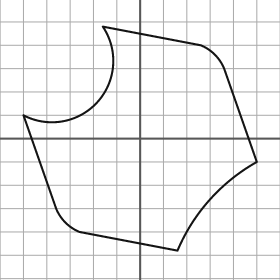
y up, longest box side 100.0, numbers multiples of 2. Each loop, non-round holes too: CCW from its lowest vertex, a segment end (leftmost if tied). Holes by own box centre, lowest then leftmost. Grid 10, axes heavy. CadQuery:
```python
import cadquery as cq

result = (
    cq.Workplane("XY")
    .moveTo(16.0, -48.0)
    .threePointArc((30.0, -26.0), (50.0, -10.0))
    .lineTo(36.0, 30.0)
    .threePointArc((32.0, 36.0), (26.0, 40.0))
    .lineTo(-16.0, 48.0)
    .threePointArc((-18.0, 16.0), (-50.0, 10.0))
    .lineTo(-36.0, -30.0)
    .threePointArc((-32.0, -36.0), (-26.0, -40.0))
    .close()
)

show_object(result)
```